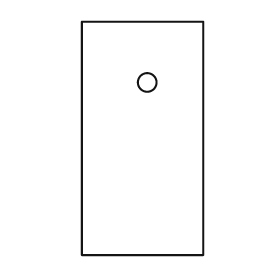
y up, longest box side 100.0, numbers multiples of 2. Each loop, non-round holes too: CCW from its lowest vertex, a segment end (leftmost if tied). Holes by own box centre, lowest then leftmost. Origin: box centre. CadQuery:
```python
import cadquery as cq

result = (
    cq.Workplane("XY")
    .moveTo(-26.0, -50.0)
    .lineTo(26.0, -50.0)
    .lineTo(26.0, 50.0)
    .lineTo(-26.0, 50.0)
    .close()
    .moveTo(2.0, 24.0)
    .circle(4.0)
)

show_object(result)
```